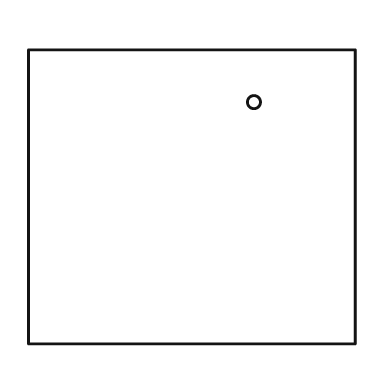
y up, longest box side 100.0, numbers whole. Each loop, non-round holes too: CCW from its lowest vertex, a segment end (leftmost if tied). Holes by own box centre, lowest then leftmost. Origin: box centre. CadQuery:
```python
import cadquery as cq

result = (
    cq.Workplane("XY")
    .moveTo(-50.0, -45.0)
    .lineTo(50.0, -45.0)
    .lineTo(50.0, 45.0)
    .lineTo(-50.0, 45.0)
    .close()
    .moveTo(19.0, 29.0)
    .circle(2.0)
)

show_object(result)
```